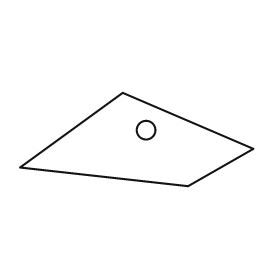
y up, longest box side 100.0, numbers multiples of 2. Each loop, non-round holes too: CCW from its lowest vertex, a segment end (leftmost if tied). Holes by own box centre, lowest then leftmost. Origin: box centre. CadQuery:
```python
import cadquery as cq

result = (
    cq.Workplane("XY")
    .moveTo(22.0, -20.0)
    .lineTo(50.0, -4.0)
    .lineTo(-6.0, 20.0)
    .lineTo(-50.0, -12.0)
    .close()
    .moveTo(4.0, 4.0)
    .circle(4.0)
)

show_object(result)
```